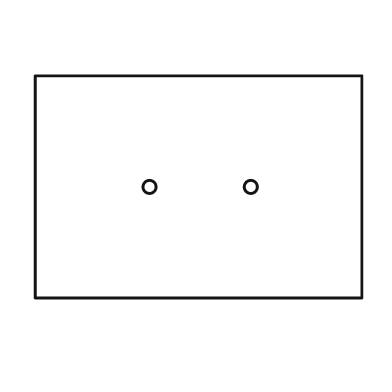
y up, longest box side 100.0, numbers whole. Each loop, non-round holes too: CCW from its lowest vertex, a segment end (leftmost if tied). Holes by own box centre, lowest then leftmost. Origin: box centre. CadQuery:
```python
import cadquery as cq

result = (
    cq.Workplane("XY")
    .moveTo(-50.0, -34.0)
    .lineTo(50.0, -34.0)
    .lineTo(50.0, 34.0)
    .lineTo(-50.0, 34.0)
    .close()
    .moveTo(-15.0, 0.0)
    .circle(2.0)
    .moveTo(16.0, 0.0)
    .circle(2.0)
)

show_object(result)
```